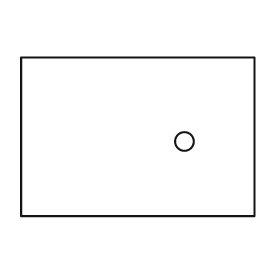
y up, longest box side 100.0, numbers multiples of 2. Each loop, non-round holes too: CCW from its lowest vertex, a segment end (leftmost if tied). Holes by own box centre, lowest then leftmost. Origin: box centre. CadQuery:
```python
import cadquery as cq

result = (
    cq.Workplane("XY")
    .moveTo(-50.0, -34.0)
    .lineTo(50.0, -34.0)
    .lineTo(50.0, 34.0)
    .lineTo(-50.0, 34.0)
    .close()
    .moveTo(20.0, -2.0)
    .circle(4.0)
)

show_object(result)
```